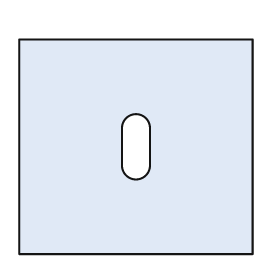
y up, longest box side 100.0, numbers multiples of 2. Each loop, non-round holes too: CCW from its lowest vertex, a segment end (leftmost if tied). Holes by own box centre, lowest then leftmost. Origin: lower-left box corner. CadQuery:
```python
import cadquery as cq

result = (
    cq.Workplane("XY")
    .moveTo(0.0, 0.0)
    .lineTo(100.0, 0.0)
    .lineTo(100.0, 92.0)
    .lineTo(0.0, 92.0)
    .close()
    .moveTo(44.0, 38.0)
    .threePointArc((50.0, 32.0), (56.0, 38.0))
    .lineTo(56.0, 54.0)
    .threePointArc((50.0, 60.0), (44.0, 54.0))
    .close()
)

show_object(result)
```